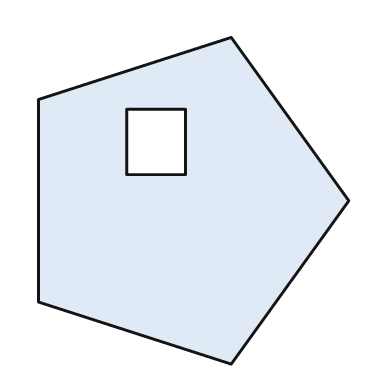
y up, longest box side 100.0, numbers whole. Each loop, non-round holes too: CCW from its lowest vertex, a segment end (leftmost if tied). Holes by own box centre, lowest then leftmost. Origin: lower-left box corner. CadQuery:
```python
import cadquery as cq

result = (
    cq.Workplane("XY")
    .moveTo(59.0, 0.0)
    .lineTo(95.0, 50.0)
    .lineTo(59.0, 100.0)
    .lineTo(0.0, 81.0)
    .lineTo(0.0, 19.0)
    .close()
    .moveTo(27.0, 58.0)
    .lineTo(45.0, 58.0)
    .lineTo(45.0, 78.0)
    .lineTo(27.0, 78.0)
    .close()
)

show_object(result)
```